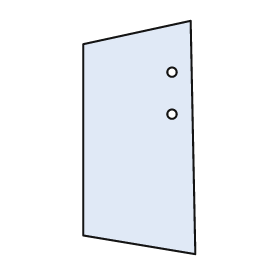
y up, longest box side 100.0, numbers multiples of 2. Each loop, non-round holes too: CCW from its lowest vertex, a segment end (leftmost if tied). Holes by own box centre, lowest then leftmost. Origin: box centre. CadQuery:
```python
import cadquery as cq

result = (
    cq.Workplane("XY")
    .moveTo(24.0, -50.0)
    .lineTo(22.0, 50.0)
    .lineTo(-24.0, 40.0)
    .lineTo(-24.0, -42.0)
    .close()
    .moveTo(14.0, 10.0)
    .circle(2.0)
    .moveTo(14.0, 28.0)
    .circle(2.0)
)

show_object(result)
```